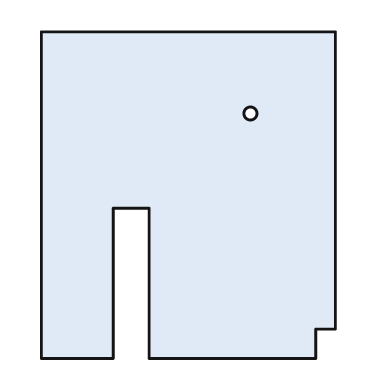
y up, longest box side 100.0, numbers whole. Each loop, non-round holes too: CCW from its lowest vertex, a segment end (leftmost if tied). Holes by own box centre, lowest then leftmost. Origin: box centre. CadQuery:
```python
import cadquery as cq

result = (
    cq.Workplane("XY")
    .moveTo(-45.0, -50.0)
    .lineTo(-23.0, -50.0)
    .lineTo(-23.0, -4.0)
    .lineTo(-12.0, -4.0)
    .lineTo(-12.0, -50.0)
    .lineTo(39.0, -50.0)
    .lineTo(39.0, -41.0)
    .lineTo(45.0, -41.0)
    .lineTo(45.0, 50.0)
    .lineTo(-45.0, 50.0)
    .close()
    .moveTo(19.0, 25.0)
    .circle(2.0)
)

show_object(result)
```